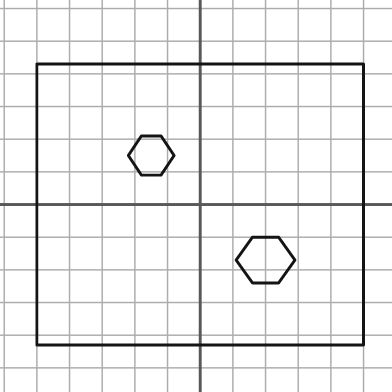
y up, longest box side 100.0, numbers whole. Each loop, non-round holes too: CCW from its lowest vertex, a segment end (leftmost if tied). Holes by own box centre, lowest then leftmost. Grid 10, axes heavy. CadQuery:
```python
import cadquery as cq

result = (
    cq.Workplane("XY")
    .moveTo(-50.0, -43.0)
    .lineTo(50.0, -43.0)
    .lineTo(50.0, 43.0)
    .lineTo(-50.0, 43.0)
    .close()
    .moveTo(16.0, -24.0)
    .lineTo(24.0, -24.0)
    .lineTo(29.0, -17.0)
    .lineTo(24.0, -10.0)
    .lineTo(16.0, -10.0)
    .lineTo(11.0, -17.0)
    .close()
    .moveTo(-18.0, 9.0)
    .lineTo(-12.0, 9.0)
    .lineTo(-8.0, 15.0)
    .lineTo(-12.0, 21.0)
    .lineTo(-18.0, 21.0)
    .lineTo(-22.0, 15.0)
    .close()
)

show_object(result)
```